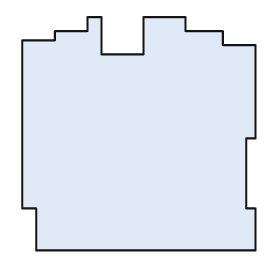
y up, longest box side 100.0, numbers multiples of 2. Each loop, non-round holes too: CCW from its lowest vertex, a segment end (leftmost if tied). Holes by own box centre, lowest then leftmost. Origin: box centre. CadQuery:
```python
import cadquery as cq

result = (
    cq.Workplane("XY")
    .moveTo(-44.0, -50.0)
    .lineTo(50.0, -50.0)
    .lineTo(50.0, -32.0)
    .lineTo(46.0, -32.0)
    .lineTo(46.0, -2.0)
    .lineTo(50.0, -2.0)
    .lineTo(50.0, 38.0)
    .lineTo(36.0, 38.0)
    .lineTo(36.0, 44.0)
    .lineTo(20.0, 44.0)
    .lineTo(20.0, 50.0)
    .lineTo(2.0, 50.0)
    .lineTo(2.0, 34.0)
    .lineTo(-16.0, 34.0)
    .lineTo(-16.0, 50.0)
    .lineTo(-22.0, 50.0)
    .lineTo(-22.0, 44.0)
    .lineTo(-36.0, 44.0)
    .lineTo(-36.0, 40.0)
    .lineTo(-50.0, 40.0)
    .lineTo(-50.0, -32.0)
    .lineTo(-44.0, -32.0)
    .close()
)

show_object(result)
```